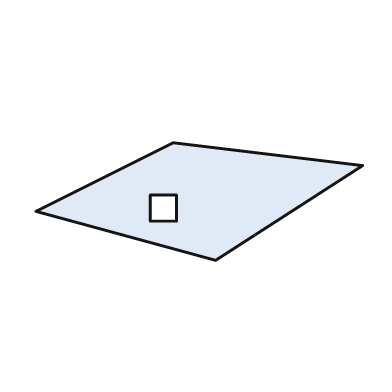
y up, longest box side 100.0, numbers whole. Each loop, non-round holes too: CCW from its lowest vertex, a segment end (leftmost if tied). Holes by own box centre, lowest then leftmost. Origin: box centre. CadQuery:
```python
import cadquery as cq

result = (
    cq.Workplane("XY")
    .moveTo(5.0, -18.0)
    .lineTo(50.0, 11.0)
    .lineTo(-8.0, 18.0)
    .lineTo(-50.0, -3.0)
    .close()
    .moveTo(-15.0, -6.0)
    .lineTo(-7.0, -6.0)
    .lineTo(-7.0, 2.0)
    .lineTo(-15.0, 2.0)
    .close()
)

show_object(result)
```